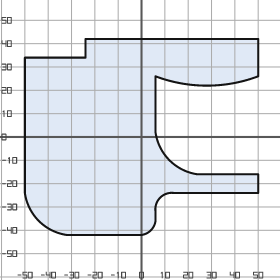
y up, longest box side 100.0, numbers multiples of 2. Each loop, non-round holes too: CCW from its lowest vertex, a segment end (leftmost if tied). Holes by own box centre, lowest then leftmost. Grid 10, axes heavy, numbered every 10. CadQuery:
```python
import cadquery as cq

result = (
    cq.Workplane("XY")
    .moveTo(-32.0, -42.0)
    .lineTo(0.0, -42.0)
    .threePointArc((4.0, -40.0), (6.0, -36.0))
    .lineTo(6.0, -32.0)
    .threePointArc((8.0, -26.0), (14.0, -24.0))
    .lineTo(50.0, -24.0)
    .lineTo(50.0, -16.0)
    .lineTo(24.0, -16.0)
    .threePointArc((12.0, -10.0), (6.0, 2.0))
    .lineTo(6.0, 26.0)
    .threePointArc((28.0, 22.0), (50.0, 26.0))
    .lineTo(50.0, 42.0)
    .lineTo(-24.0, 42.0)
    .lineTo(-24.0, 34.0)
    .lineTo(-50.0, 34.0)
    .lineTo(-50.0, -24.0)
    .threePointArc((-44.0, -36.0), (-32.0, -42.0))
    .close()
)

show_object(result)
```